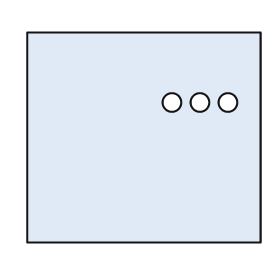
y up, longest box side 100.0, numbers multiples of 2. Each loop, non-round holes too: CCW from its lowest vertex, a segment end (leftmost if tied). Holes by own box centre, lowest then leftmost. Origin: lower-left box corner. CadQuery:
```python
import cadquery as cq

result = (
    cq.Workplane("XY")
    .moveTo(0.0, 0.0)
    .lineTo(100.0, 0.0)
    .lineTo(100.0, 90.0)
    .lineTo(0.0, 90.0)
    .close()
    .moveTo(62.0, 60.0)
    .circle(4.0)
    .moveTo(74.0, 60.0)
    .circle(4.0)
    .moveTo(86.0, 60.0)
    .circle(4.0)
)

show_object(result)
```